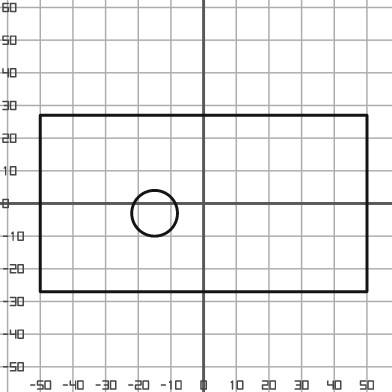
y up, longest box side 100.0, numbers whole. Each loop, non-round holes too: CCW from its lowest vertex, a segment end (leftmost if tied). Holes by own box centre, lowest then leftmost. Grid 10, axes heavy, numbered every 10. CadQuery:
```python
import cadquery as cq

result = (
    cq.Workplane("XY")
    .moveTo(-50.0, -27.0)
    .lineTo(50.0, -27.0)
    .lineTo(50.0, 27.0)
    .lineTo(-50.0, 27.0)
    .close()
    .moveTo(-15.0, -3.0)
    .circle(7.0)
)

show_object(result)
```